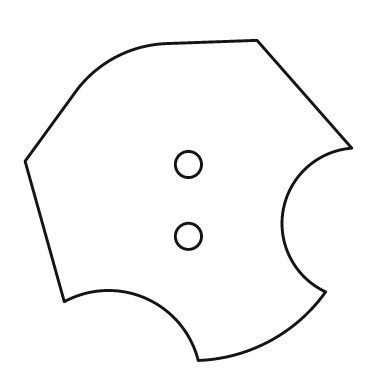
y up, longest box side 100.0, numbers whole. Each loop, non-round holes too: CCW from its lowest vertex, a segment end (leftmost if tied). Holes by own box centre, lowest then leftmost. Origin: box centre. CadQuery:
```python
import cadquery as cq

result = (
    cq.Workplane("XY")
    .moveTo(3.0, -49.0)
    .threePointArc((25.0, -43.0), (42.0, -28.0))
    .threePointArc((29.0, -3.0), (50.0, 16.0))
    .lineTo(21.0, 49.0)
    .lineTo(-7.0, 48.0)
    .threePointArc((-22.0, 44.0), (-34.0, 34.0))
    .lineTo(-50.0, 12.0)
    .lineTo(-38.0, -31.0)
    .threePointArc((-13.0, -30.0), (3.0, -49.0))
    .close()
    .moveTo(0.0, -11.0)
    .circle(4.0)
    .moveTo(0.0, 11.0)
    .circle(4.0)
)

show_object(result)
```